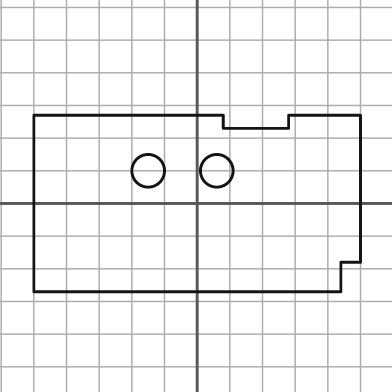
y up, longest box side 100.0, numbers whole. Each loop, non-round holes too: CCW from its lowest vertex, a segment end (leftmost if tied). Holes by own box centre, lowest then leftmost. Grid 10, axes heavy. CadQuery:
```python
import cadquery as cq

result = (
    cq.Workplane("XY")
    .moveTo(-50.0, -27.0)
    .lineTo(44.0, -27.0)
    .lineTo(44.0, -18.0)
    .lineTo(50.0, -18.0)
    .lineTo(50.0, 27.0)
    .lineTo(28.0, 27.0)
    .lineTo(28.0, 23.0)
    .lineTo(8.0, 23.0)
    .lineTo(8.0, 27.0)
    .lineTo(-50.0, 27.0)
    .close()
    .moveTo(-15.0, 10.0)
    .circle(5.0)
    .moveTo(6.0, 10.0)
    .circle(5.0)
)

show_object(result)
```